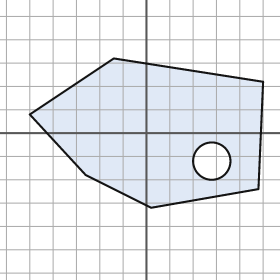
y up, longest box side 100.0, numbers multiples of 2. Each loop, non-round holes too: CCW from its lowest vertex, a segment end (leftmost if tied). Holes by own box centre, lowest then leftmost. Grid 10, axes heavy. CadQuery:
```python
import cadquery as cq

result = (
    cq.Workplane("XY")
    .moveTo(2.0, -32.0)
    .lineTo(48.0, -24.0)
    .lineTo(50.0, 22.0)
    .lineTo(-14.0, 32.0)
    .lineTo(-50.0, 8.0)
    .lineTo(-26.0, -18.0)
    .close()
    .moveTo(28.0, -12.0)
    .circle(8.0)
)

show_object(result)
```